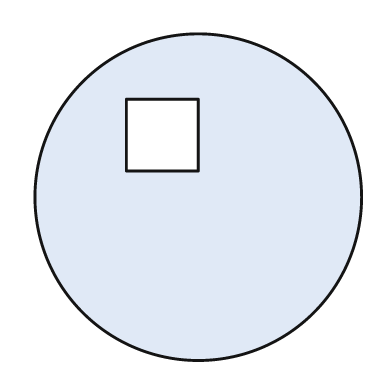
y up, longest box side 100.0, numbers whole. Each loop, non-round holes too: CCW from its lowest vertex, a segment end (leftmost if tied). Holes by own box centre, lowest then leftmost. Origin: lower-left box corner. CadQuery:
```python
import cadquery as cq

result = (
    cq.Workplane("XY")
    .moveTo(50.0, 50.0)
    .circle(50.0)
    .moveTo(28.0, 58.0)
    .lineTo(50.0, 58.0)
    .lineTo(50.0, 80.0)
    .lineTo(28.0, 80.0)
    .close()
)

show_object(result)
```